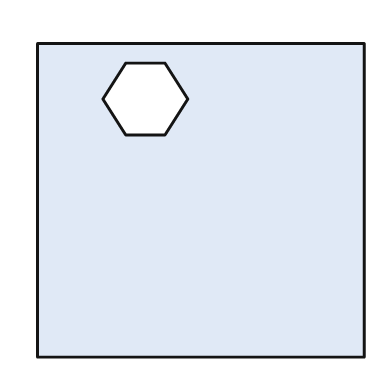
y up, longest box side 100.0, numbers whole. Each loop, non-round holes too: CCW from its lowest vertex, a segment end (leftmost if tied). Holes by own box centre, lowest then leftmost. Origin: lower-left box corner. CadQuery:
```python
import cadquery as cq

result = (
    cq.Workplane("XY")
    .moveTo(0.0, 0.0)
    .lineTo(100.0, 0.0)
    .lineTo(100.0, 96.0)
    .lineTo(0.0, 96.0)
    .close()
    .moveTo(27.0, 68.0)
    .lineTo(39.0, 68.0)
    .lineTo(46.0, 79.0)
    .lineTo(39.0, 90.0)
    .lineTo(27.0, 90.0)
    .lineTo(20.0, 79.0)
    .close()
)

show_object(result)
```